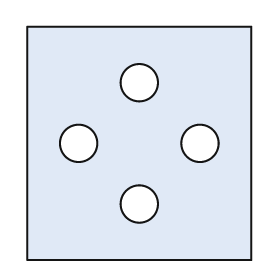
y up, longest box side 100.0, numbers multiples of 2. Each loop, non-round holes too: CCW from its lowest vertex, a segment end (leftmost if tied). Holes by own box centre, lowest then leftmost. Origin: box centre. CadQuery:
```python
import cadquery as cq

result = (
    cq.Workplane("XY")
    .moveTo(-48.0, -50.0)
    .lineTo(48.0, -50.0)
    .lineTo(48.0, 50.0)
    .lineTo(-48.0, 50.0)
    .close()
    .moveTo(0.0, -26.0)
    .circle(8.0)
    .moveTo(-26.0, 0.0)
    .circle(8.0)
    .moveTo(26.0, 0.0)
    .circle(8.0)
    .moveTo(0.0, 26.0)
    .circle(8.0)
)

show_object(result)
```